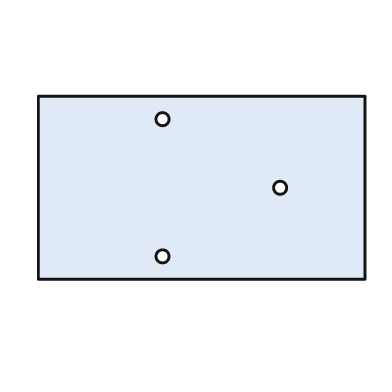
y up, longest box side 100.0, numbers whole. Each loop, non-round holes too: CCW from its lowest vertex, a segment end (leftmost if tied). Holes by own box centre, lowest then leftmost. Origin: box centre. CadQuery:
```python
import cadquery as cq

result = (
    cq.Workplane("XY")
    .moveTo(-50.0, -28.0)
    .lineTo(50.0, -28.0)
    .lineTo(50.0, 28.0)
    .lineTo(-50.0, 28.0)
    .close()
    .moveTo(-12.0, -21.0)
    .circle(2.0)
    .moveTo(24.0, 0.0)
    .circle(2.0)
    .moveTo(-12.0, 21.0)
    .circle(2.0)
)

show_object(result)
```